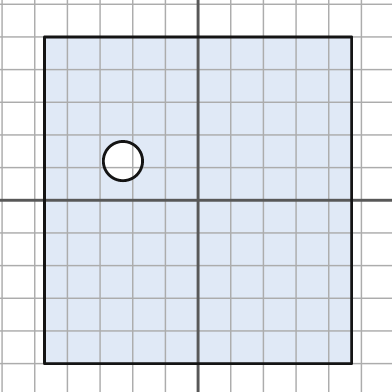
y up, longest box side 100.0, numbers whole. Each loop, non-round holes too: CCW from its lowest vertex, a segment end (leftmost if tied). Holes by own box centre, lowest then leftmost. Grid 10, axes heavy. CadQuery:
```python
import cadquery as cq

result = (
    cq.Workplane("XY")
    .moveTo(-47.0, -50.0)
    .lineTo(47.0, -50.0)
    .lineTo(47.0, 50.0)
    .lineTo(-47.0, 50.0)
    .close()
    .moveTo(-23.0, 12.0)
    .circle(6.0)
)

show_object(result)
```